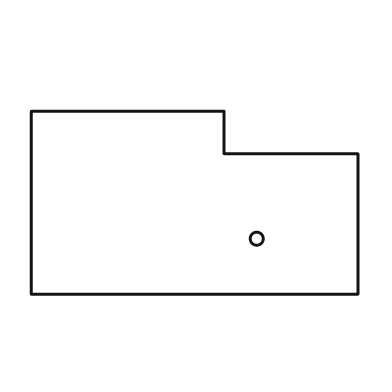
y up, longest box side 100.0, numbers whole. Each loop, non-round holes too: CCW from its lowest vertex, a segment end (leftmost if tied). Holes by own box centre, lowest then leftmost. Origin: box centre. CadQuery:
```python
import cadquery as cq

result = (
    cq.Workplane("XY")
    .moveTo(-50.0, -28.0)
    .lineTo(50.0, -28.0)
    .lineTo(50.0, 15.0)
    .lineTo(9.0, 15.0)
    .lineTo(9.0, 28.0)
    .lineTo(-50.0, 28.0)
    .close()
    .moveTo(19.0, -11.0)
    .circle(2.0)
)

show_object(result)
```